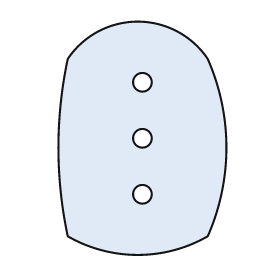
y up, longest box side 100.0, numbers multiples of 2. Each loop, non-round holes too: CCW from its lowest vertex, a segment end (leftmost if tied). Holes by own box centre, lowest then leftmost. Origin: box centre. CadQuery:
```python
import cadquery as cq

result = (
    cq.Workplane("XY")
    .moveTo(-32.0, -42.0)
    .threePointArc((-2.0, -50.0), (28.0, -42.0))
    .threePointArc((36.0, -4.0), (28.0, 34.0))
    .threePointArc((-2.0, 50.0), (-32.0, 34.0))
    .threePointArc((-36.0, -4.0), (-32.0, -42.0))
    .close()
    .moveTo(0.0, -24.0)
    .circle(4.0)
    .moveTo(0.0, 0.0)
    .circle(4.0)
    .moveTo(0.0, 24.0)
    .circle(4.0)
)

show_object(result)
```